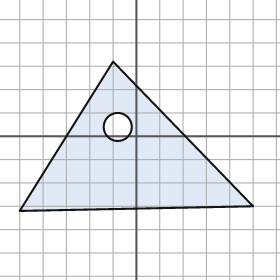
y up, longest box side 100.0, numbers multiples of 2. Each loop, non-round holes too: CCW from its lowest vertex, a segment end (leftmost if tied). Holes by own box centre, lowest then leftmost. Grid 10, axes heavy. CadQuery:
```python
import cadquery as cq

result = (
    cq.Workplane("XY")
    .moveTo(-50.0, -32.0)
    .lineTo(50.0, -30.0)
    .lineTo(-10.0, 32.0)
    .close()
    .moveTo(-8.0, 4.0)
    .circle(6.0)
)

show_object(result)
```